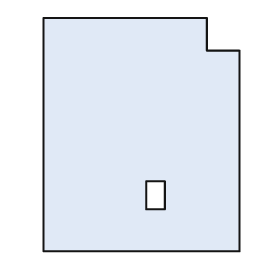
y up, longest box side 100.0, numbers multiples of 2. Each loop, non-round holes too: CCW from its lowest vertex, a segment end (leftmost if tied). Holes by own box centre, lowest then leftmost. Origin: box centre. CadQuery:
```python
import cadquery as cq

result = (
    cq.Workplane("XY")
    .moveTo(-42.0, -50.0)
    .lineTo(42.0, -50.0)
    .lineTo(42.0, 36.0)
    .lineTo(28.0, 36.0)
    .lineTo(28.0, 50.0)
    .lineTo(-42.0, 50.0)
    .close()
    .moveTo(2.0, -32.0)
    .lineTo(10.0, -32.0)
    .lineTo(10.0, -20.0)
    .lineTo(2.0, -20.0)
    .close()
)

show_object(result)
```